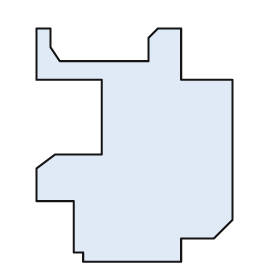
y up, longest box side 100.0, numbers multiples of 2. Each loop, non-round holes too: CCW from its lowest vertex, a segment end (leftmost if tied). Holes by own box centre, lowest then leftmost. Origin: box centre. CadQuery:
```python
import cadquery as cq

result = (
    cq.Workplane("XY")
    .moveTo(-22.0, -50.0)
    .lineTo(20.0, -50.0)
    .lineTo(20.0, -40.0)
    .lineTo(34.0, -40.0)
    .lineTo(42.0, -32.0)
    .lineTo(42.0, 28.0)
    .lineTo(20.0, 28.0)
    .lineTo(20.0, 50.0)
    .lineTo(10.0, 50.0)
    .lineTo(6.0, 46.0)
    .lineTo(6.0, 36.0)
    .lineTo(-32.0, 36.0)
    .lineTo(-36.0, 42.0)
    .lineTo(-36.0, 50.0)
    .lineTo(-42.0, 50.0)
    .lineTo(-42.0, 28.0)
    .lineTo(-14.0, 28.0)
    .lineTo(-14.0, -4.0)
    .lineTo(-34.0, -4.0)
    .lineTo(-42.0, -10.0)
    .lineTo(-42.0, -24.0)
    .lineTo(-26.0, -24.0)
    .lineTo(-26.0, -46.0)
    .lineTo(-22.0, -46.0)
    .close()
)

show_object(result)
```